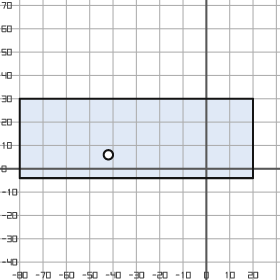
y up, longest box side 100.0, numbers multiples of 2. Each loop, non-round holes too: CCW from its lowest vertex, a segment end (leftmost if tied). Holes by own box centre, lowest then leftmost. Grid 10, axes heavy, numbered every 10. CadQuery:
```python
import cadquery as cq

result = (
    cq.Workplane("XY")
    .moveTo(-80.0, -4.0)
    .lineTo(20.0, -4.0)
    .lineTo(20.0, 30.0)
    .lineTo(-80.0, 30.0)
    .close()
    .moveTo(-42.0, 6.0)
    .circle(2.0)
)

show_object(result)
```